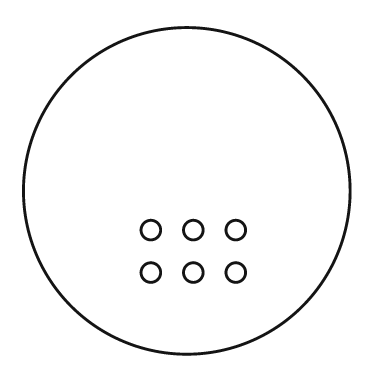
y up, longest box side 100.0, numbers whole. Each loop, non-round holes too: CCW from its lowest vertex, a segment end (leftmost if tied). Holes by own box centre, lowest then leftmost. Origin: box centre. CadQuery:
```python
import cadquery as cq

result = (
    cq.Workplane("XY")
    .moveTo(0.0, 0.0)
    .circle(50.0)
    .moveTo(-11.0, -25.0)
    .circle(3.0)
    .moveTo(2.0, -25.0)
    .circle(3.0)
    .moveTo(15.0, -25.0)
    .circle(3.0)
    .moveTo(-11.0, -12.0)
    .circle(3.0)
    .moveTo(2.0, -12.0)
    .circle(3.0)
    .moveTo(15.0, -12.0)
    .circle(3.0)
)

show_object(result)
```